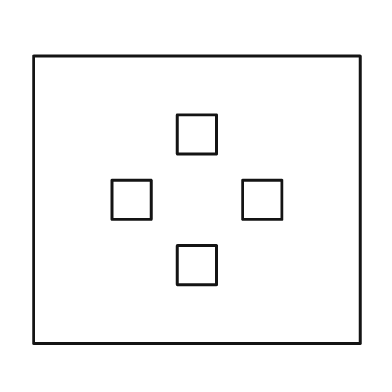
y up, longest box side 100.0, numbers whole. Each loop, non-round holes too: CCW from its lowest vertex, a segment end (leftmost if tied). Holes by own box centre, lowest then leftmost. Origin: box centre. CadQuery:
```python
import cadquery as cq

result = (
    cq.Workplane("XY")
    .moveTo(-50.0, -44.0)
    .lineTo(50.0, -44.0)
    .lineTo(50.0, 44.0)
    .lineTo(-50.0, 44.0)
    .close()
    .moveTo(-6.0, -26.0)
    .lineTo(6.0, -26.0)
    .lineTo(6.0, -14.0)
    .lineTo(-6.0, -14.0)
    .close()
    .moveTo(-26.0, -6.0)
    .lineTo(-14.0, -6.0)
    .lineTo(-14.0, 6.0)
    .lineTo(-26.0, 6.0)
    .close()
    .moveTo(14.0, -6.0)
    .lineTo(26.0, -6.0)
    .lineTo(26.0, 6.0)
    .lineTo(14.0, 6.0)
    .close()
    .moveTo(-6.0, 14.0)
    .lineTo(6.0, 14.0)
    .lineTo(6.0, 26.0)
    .lineTo(-6.0, 26.0)
    .close()
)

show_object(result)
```